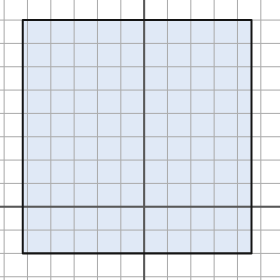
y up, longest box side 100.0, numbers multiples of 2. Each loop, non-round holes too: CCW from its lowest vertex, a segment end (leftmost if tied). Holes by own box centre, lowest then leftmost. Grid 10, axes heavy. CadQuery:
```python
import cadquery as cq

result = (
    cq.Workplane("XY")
    .moveTo(-52.0, -20.0)
    .lineTo(46.0, -20.0)
    .lineTo(46.0, 80.0)
    .lineTo(-52.0, 80.0)
    .close()
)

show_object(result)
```